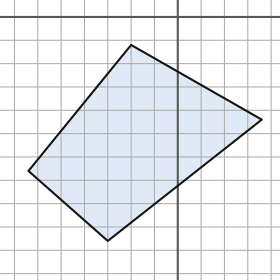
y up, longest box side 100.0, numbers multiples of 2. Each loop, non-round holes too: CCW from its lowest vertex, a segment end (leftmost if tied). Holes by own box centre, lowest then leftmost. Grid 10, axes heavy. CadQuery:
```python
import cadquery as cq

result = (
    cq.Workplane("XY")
    .moveTo(-30.0, -96.0)
    .lineTo(36.0, -44.0)
    .lineTo(-20.0, -12.0)
    .lineTo(-64.0, -66.0)
    .close()
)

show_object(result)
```